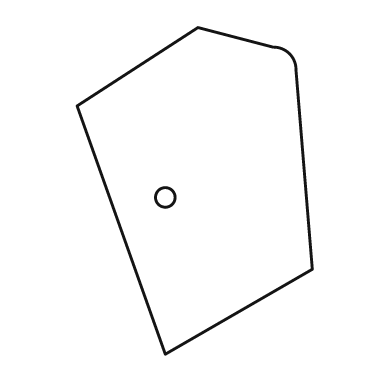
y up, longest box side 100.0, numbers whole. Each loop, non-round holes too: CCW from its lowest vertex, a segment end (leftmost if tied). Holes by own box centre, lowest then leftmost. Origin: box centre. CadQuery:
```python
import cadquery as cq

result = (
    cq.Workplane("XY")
    .moveTo(-9.0, -50.0)
    .lineTo(36.0, -24.0)
    .lineTo(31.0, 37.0)
    .threePointArc((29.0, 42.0), (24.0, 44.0))
    .lineTo(1.0, 50.0)
    .lineTo(-36.0, 26.0)
    .close()
    .moveTo(-9.0, -2.0)
    .circle(3.0)
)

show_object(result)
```